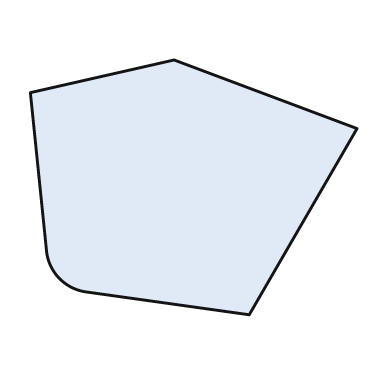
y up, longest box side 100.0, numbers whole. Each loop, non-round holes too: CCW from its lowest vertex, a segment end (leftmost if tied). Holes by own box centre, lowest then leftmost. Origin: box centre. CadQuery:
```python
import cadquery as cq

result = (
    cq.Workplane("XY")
    .moveTo(17.0, -39.0)
    .lineTo(50.0, 18.0)
    .lineTo(-6.0, 39.0)
    .lineTo(-50.0, 29.0)
    .lineTo(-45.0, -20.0)
    .threePointArc((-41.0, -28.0), (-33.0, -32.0))
    .close()
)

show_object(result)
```